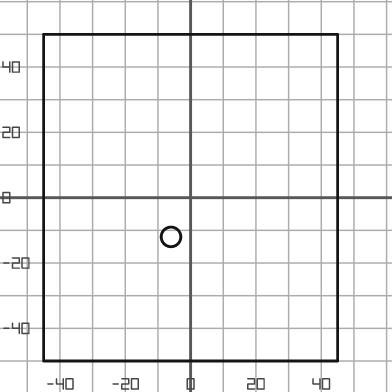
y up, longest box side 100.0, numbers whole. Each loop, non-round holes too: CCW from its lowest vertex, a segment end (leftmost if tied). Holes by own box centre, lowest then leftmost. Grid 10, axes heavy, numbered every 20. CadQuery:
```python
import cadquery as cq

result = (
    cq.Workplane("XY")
    .moveTo(-45.0, -50.0)
    .lineTo(45.0, -50.0)
    .lineTo(45.0, 50.0)
    .lineTo(-45.0, 50.0)
    .close()
    .moveTo(-6.0, -12.0)
    .circle(3.0)
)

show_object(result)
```